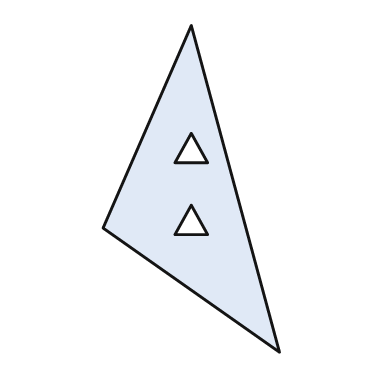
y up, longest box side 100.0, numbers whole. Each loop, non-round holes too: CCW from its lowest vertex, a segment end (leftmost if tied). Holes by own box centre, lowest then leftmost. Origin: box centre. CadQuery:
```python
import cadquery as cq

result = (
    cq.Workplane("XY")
    .moveTo(27.0, -50.0)
    .lineTo(0.0, 50.0)
    .lineTo(-27.0, -12.0)
    .close()
    .moveTo(-5.0, -14.0)
    .lineTo(5.0, -14.0)
    .lineTo(0.0, -5.0)
    .close()
    .moveTo(-5.0, 8.0)
    .lineTo(5.0, 8.0)
    .lineTo(0.0, 17.0)
    .close()
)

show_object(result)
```